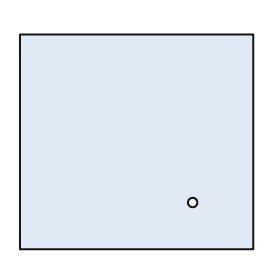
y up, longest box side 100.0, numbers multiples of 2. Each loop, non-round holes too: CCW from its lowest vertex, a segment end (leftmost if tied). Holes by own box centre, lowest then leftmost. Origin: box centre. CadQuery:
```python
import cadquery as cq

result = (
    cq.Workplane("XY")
    .moveTo(-50.0, -46.0)
    .lineTo(50.0, -46.0)
    .lineTo(50.0, 46.0)
    .lineTo(-50.0, 46.0)
    .close()
    .moveTo(24.0, -26.0)
    .circle(2.0)
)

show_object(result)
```